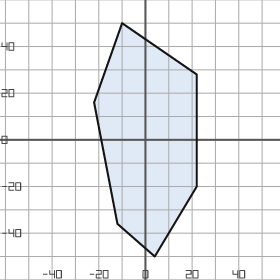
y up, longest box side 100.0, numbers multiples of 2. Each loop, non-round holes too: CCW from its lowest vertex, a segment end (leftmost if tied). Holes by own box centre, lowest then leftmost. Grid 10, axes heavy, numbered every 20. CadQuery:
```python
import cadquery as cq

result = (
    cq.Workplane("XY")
    .moveTo(4.0, -50.0)
    .lineTo(22.0, -20.0)
    .lineTo(22.0, 28.0)
    .lineTo(-10.0, 50.0)
    .lineTo(-22.0, 16.0)
    .lineTo(-12.0, -36.0)
    .close()
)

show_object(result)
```